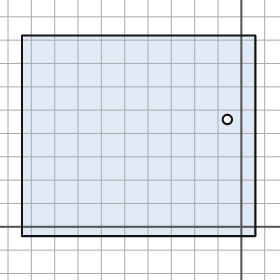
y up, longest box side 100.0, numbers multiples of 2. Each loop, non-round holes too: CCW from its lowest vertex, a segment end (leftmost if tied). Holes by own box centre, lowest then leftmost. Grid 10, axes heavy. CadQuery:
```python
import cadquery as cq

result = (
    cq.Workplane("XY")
    .moveTo(-94.0, -4.0)
    .lineTo(6.0, -4.0)
    .lineTo(6.0, 82.0)
    .lineTo(-94.0, 82.0)
    .close()
    .moveTo(-6.0, 46.0)
    .circle(2.0)
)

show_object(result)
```